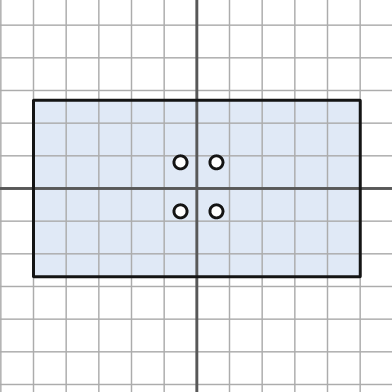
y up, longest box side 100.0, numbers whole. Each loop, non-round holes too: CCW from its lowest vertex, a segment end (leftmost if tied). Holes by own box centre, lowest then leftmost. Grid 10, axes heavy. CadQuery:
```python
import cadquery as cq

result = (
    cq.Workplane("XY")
    .moveTo(-50.0, -27.0)
    .lineTo(50.0, -27.0)
    .lineTo(50.0, 27.0)
    .lineTo(-50.0, 27.0)
    .close()
    .moveTo(-5.0, -7.0)
    .circle(2.0)
    .moveTo(6.0, -7.0)
    .circle(2.0)
    .moveTo(-5.0, 8.0)
    .circle(2.0)
    .moveTo(6.0, 8.0)
    .circle(2.0)
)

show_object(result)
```